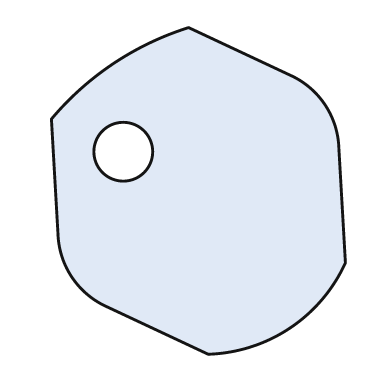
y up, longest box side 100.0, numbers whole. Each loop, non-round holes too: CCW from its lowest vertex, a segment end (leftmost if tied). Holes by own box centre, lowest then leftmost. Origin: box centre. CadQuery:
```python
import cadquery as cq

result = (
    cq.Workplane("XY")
    .moveTo(3.0, -50.0)
    .threePointArc((28.0, -42.0), (45.0, -22.0))
    .lineTo(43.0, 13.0)
    .threePointArc((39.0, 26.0), (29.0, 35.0))
    .lineTo(-3.0, 50.0)
    .threePointArc((-26.0, 39.0), (-45.0, 22.0))
    .lineTo(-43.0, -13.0)
    .threePointArc((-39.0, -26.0), (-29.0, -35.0))
    .close()
    .moveTo(-23.0, 12.0)
    .circle(9.0)
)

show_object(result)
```